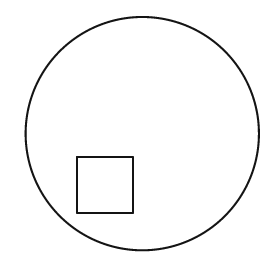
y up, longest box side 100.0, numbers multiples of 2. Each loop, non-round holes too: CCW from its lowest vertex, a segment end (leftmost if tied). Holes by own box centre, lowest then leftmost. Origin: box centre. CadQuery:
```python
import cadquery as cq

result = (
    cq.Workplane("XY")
    .moveTo(0.0, 0.0)
    .circle(50.0)
    .moveTo(-28.0, -34.0)
    .lineTo(-4.0, -34.0)
    .lineTo(-4.0, -10.0)
    .lineTo(-28.0, -10.0)
    .close()
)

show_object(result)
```